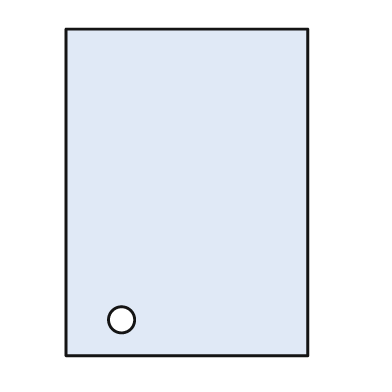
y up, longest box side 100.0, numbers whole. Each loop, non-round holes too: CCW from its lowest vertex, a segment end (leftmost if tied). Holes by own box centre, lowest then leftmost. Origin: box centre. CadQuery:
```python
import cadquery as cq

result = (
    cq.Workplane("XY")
    .moveTo(-37.0, -50.0)
    .lineTo(37.0, -50.0)
    .lineTo(37.0, 50.0)
    .lineTo(-37.0, 50.0)
    .close()
    .moveTo(-20.0, -39.0)
    .circle(4.0)
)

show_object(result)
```